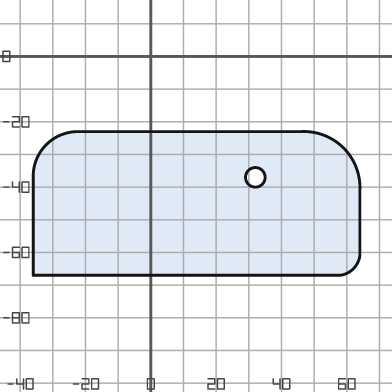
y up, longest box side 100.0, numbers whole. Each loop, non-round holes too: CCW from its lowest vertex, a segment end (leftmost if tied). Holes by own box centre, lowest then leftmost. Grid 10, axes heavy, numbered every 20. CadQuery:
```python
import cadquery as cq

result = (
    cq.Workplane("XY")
    .moveTo(-36.0, -67.0)
    .lineTo(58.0, -67.0)
    .threePointArc((62.0, -65.0), (64.0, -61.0))
    .lineTo(64.0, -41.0)
    .threePointArc((59.0, -28.0), (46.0, -23.0))
    .lineTo(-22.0, -23.0)
    .threePointArc((-32.0, -27.0), (-36.0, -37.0))
    .close()
    .moveTo(32.0, -37.0)
    .circle(3.0)
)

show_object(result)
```